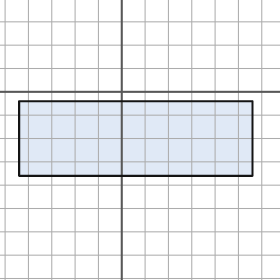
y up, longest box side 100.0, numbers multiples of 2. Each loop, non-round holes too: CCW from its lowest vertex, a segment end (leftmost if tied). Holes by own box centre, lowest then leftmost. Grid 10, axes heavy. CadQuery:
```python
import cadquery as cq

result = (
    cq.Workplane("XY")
    .moveTo(-44.0, -36.0)
    .lineTo(56.0, -36.0)
    .lineTo(56.0, -4.0)
    .lineTo(-44.0, -4.0)
    .close()
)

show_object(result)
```